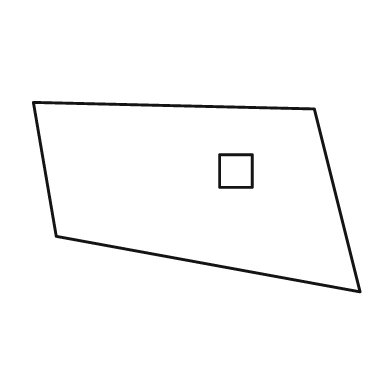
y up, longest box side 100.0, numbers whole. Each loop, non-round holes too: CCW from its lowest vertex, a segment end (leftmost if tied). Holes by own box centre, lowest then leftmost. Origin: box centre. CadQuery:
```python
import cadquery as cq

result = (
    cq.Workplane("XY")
    .moveTo(50.0, -29.0)
    .lineTo(36.0, 27.0)
    .lineTo(-50.0, 29.0)
    .lineTo(-43.0, -12.0)
    .close()
    .moveTo(7.0, 3.0)
    .lineTo(17.0, 3.0)
    .lineTo(17.0, 13.0)
    .lineTo(7.0, 13.0)
    .close()
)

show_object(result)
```